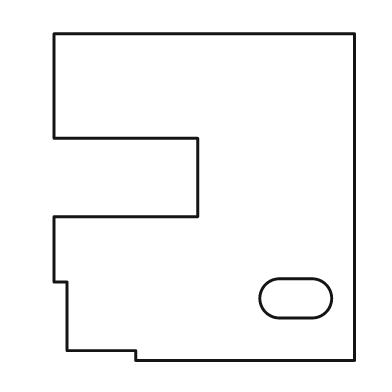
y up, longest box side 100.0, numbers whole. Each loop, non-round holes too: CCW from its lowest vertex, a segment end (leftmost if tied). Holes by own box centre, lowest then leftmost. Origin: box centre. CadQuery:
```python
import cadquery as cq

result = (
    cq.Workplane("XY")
    .moveTo(-21.0, -50.0)
    .lineTo(46.0, -50.0)
    .lineTo(46.0, 50.0)
    .lineTo(-46.0, 50.0)
    .lineTo(-46.0, 18.0)
    .lineTo(-2.0, 18.0)
    .lineTo(-2.0, -6.0)
    .lineTo(-46.0, -6.0)
    .lineTo(-46.0, -26.0)
    .lineTo(-42.0, -26.0)
    .lineTo(-42.0, -47.0)
    .lineTo(-21.0, -47.0)
    .close()
    .moveTo(23.0, -37.0)
    .lineTo(33.0, -37.0)
    .threePointArc((39.0, -31.0), (33.0, -25.0))
    .lineTo(23.0, -25.0)
    .threePointArc((17.0, -31.0), (23.0, -37.0))
    .close()
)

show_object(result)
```